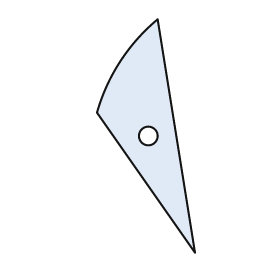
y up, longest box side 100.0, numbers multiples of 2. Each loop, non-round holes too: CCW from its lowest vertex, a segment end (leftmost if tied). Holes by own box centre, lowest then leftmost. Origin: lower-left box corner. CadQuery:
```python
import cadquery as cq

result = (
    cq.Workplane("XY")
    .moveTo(42.0, 0.0)
    .lineTo(26.0, 100.0)
    .threePointArc((10.0, 82.0), (0.0, 60.0))
    .close()
    .moveTo(22.0, 50.0)
    .circle(4.0)
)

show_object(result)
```